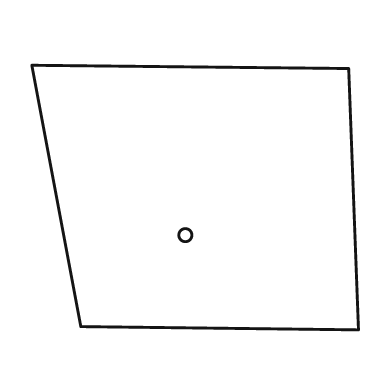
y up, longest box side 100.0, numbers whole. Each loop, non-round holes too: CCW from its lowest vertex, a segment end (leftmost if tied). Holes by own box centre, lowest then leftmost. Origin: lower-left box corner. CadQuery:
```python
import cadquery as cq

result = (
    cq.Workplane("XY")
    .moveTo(100.0, 0.0)
    .lineTo(97.0, 80.0)
    .lineTo(0.0, 81.0)
    .lineTo(15.0, 1.0)
    .close()
    .moveTo(47.0, 29.0)
    .circle(2.0)
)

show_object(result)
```